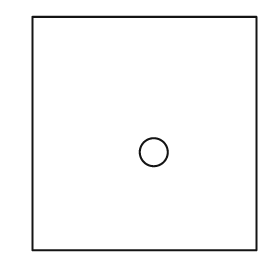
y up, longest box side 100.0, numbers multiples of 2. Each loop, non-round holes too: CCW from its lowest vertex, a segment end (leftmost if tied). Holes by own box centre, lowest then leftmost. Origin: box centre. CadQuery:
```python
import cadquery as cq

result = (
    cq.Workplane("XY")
    .moveTo(-48.0, -50.0)
    .lineTo(48.0, -50.0)
    .lineTo(48.0, 50.0)
    .lineTo(-48.0, 50.0)
    .close()
    .moveTo(4.0, -8.0)
    .circle(6.0)
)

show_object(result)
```